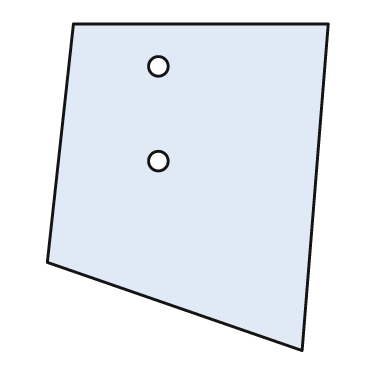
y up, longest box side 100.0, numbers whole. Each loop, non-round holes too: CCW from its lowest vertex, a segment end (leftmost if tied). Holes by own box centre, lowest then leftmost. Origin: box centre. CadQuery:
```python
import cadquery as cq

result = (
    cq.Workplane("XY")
    .moveTo(35.0, -50.0)
    .lineTo(43.0, 50.0)
    .lineTo(-35.0, 50.0)
    .lineTo(-43.0, -23.0)
    .close()
    .moveTo(-9.0, 8.0)
    .circle(3.0)
    .moveTo(-9.0, 37.0)
    .circle(3.0)
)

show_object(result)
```